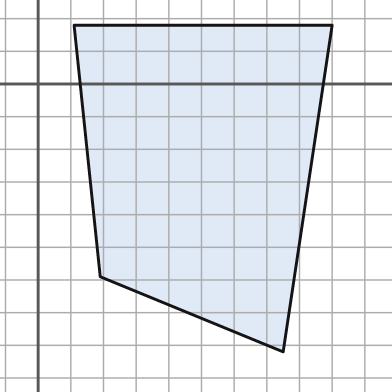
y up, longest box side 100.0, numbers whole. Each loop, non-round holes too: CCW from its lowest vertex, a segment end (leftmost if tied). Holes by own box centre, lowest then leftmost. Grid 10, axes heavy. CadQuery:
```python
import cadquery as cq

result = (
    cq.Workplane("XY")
    .moveTo(75.0, -82.0)
    .lineTo(90.0, 18.0)
    .lineTo(11.0, 18.0)
    .lineTo(19.0, -59.0)
    .close()
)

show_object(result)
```